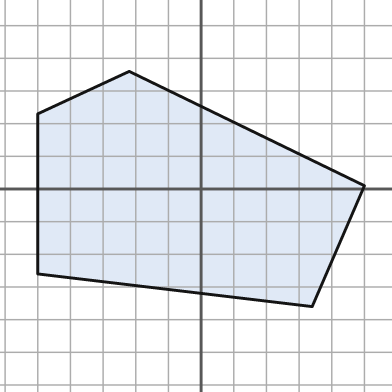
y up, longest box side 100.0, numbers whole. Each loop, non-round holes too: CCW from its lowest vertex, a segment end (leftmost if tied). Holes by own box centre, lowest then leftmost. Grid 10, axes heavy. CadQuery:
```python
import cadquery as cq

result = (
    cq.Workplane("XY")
    .moveTo(34.0, -36.0)
    .lineTo(50.0, 1.0)
    .lineTo(-22.0, 36.0)
    .lineTo(-50.0, 23.0)
    .lineTo(-50.0, -26.0)
    .close()
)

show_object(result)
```